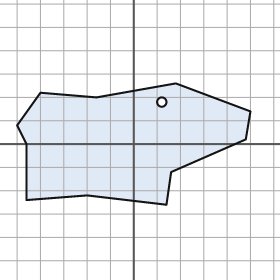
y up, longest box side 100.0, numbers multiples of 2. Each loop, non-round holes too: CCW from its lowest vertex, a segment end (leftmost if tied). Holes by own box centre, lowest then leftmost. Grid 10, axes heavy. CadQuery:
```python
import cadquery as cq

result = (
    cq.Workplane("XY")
    .moveTo(14.0, -26.0)
    .lineTo(16.0, -12.0)
    .lineTo(48.0, 2.0)
    .lineTo(50.0, 14.0)
    .lineTo(18.0, 26.0)
    .lineTo(-16.0, 20.0)
    .lineTo(-40.0, 22.0)
    .lineTo(-50.0, 8.0)
    .lineTo(-46.0, 0.0)
    .lineTo(-46.0, -24.0)
    .lineTo(-20.0, -22.0)
    .close()
    .moveTo(12.0, 18.0)
    .circle(2.0)
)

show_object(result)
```